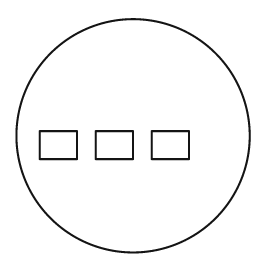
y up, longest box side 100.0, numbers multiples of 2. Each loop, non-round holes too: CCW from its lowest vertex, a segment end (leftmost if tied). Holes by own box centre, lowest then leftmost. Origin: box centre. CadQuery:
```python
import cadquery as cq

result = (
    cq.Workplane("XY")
    .moveTo(0.0, 0.0)
    .circle(50.0)
    .moveTo(-40.0, -10.0)
    .lineTo(-24.0, -10.0)
    .lineTo(-24.0, 2.0)
    .lineTo(-40.0, 2.0)
    .close()
    .moveTo(-16.0, -10.0)
    .lineTo(0.0, -10.0)
    .lineTo(0.0, 2.0)
    .lineTo(-16.0, 2.0)
    .close()
    .moveTo(8.0, -10.0)
    .lineTo(24.0, -10.0)
    .lineTo(24.0, 2.0)
    .lineTo(8.0, 2.0)
    .close()
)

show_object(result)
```